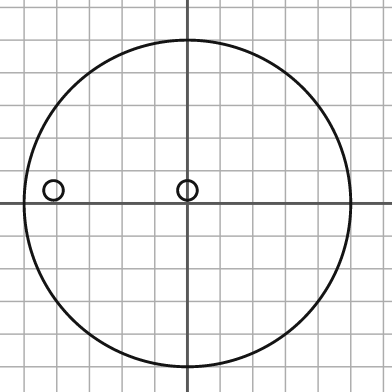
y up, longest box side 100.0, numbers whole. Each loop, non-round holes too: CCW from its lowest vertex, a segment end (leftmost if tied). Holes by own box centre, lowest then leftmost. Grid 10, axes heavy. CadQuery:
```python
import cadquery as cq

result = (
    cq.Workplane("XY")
    .moveTo(0.0, 0.0)
    .circle(50.0)
    .moveTo(-41.0, 4.0)
    .circle(3.0)
    .moveTo(0.0, 4.0)
    .circle(3.0)
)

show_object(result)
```